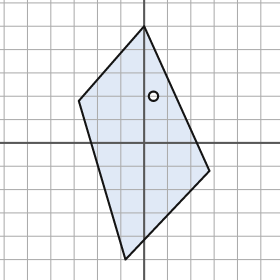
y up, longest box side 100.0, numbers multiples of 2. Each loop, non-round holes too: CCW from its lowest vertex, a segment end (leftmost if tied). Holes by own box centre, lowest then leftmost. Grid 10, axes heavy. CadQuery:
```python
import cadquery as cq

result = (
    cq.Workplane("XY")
    .moveTo(-8.0, -50.0)
    .lineTo(28.0, -12.0)
    .lineTo(0.0, 50.0)
    .lineTo(-28.0, 18.0)
    .close()
    .moveTo(4.0, 20.0)
    .circle(2.0)
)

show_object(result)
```